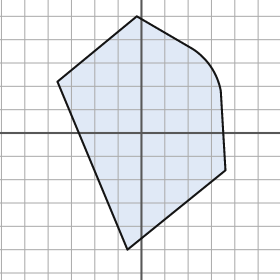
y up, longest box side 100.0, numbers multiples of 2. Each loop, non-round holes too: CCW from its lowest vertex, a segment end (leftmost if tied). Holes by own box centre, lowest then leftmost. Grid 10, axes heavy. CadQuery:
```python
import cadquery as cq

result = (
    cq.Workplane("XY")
    .moveTo(-6.0, -50.0)
    .lineTo(36.0, -16.0)
    .lineTo(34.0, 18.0)
    .threePointArc((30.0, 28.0), (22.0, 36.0))
    .lineTo(-2.0, 50.0)
    .lineTo(-36.0, 22.0)
    .close()
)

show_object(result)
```